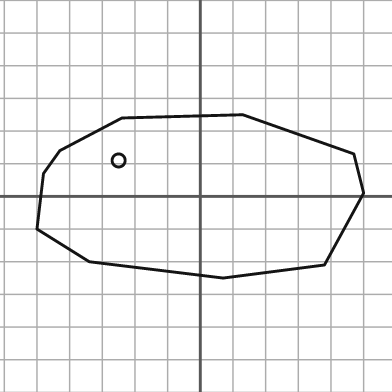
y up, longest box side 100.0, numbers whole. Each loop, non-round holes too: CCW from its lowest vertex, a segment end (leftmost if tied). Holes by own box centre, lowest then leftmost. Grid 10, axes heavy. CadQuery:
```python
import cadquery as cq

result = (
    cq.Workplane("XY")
    .moveTo(7.0, -25.0)
    .lineTo(38.0, -21.0)
    .lineTo(50.0, 1.0)
    .lineTo(47.0, 13.0)
    .lineTo(13.0, 25.0)
    .lineTo(-24.0, 24.0)
    .lineTo(-43.0, 14.0)
    .lineTo(-48.0, 7.0)
    .lineTo(-50.0, -10.0)
    .lineTo(-34.0, -20.0)
    .close()
    .moveTo(-25.0, 11.0)
    .circle(2.0)
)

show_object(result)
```